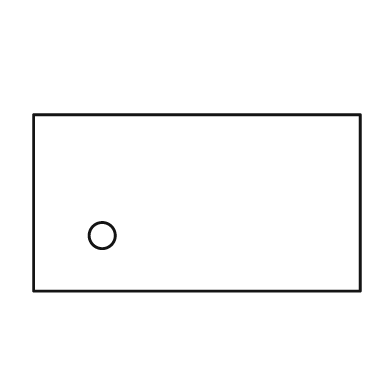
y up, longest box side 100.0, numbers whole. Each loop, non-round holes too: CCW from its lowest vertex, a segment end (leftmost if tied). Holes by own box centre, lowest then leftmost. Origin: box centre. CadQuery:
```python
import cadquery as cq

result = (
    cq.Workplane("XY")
    .moveTo(-50.0, -27.0)
    .lineTo(50.0, -27.0)
    .lineTo(50.0, 27.0)
    .lineTo(-50.0, 27.0)
    .close()
    .moveTo(-29.0, -10.0)
    .circle(4.0)
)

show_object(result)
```